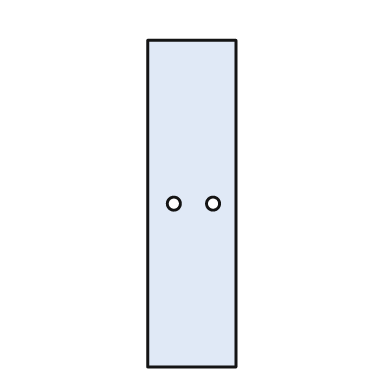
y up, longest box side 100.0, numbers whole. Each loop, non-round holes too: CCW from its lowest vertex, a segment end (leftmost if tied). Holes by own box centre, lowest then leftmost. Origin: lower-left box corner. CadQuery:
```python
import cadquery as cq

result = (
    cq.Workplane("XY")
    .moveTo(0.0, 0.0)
    .lineTo(27.0, 0.0)
    .lineTo(27.0, 100.0)
    .lineTo(0.0, 100.0)
    .close()
    .moveTo(8.0, 50.0)
    .circle(2.0)
    .moveTo(20.0, 50.0)
    .circle(2.0)
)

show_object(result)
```